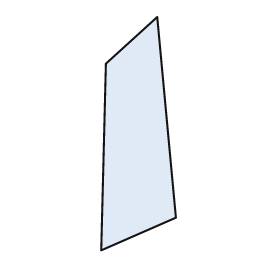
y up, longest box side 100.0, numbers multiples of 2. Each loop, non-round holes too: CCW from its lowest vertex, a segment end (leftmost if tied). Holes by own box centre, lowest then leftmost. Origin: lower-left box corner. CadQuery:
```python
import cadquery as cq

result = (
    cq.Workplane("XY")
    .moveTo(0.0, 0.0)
    .lineTo(32.0, 14.0)
    .lineTo(24.0, 100.0)
    .lineTo(2.0, 80.0)
    .close()
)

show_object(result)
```